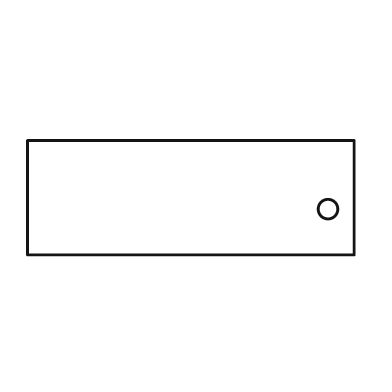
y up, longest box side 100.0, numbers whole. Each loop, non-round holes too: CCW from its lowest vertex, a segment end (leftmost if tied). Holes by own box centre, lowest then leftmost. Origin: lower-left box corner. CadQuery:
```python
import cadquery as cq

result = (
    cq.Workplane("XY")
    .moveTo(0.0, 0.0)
    .lineTo(100.0, 0.0)
    .lineTo(100.0, 35.0)
    .lineTo(0.0, 35.0)
    .close()
    .moveTo(92.0, 14.0)
    .circle(3.0)
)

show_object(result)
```